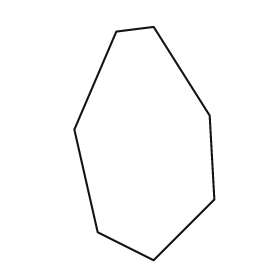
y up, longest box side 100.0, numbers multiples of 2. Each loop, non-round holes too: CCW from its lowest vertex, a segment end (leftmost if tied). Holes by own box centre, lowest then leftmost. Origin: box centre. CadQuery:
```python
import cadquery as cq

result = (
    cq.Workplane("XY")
    .moveTo(4.0, -50.0)
    .lineTo(30.0, -24.0)
    .lineTo(28.0, 12.0)
    .lineTo(4.0, 50.0)
    .lineTo(-12.0, 48.0)
    .lineTo(-30.0, 6.0)
    .lineTo(-20.0, -38.0)
    .close()
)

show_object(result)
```